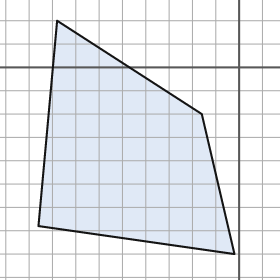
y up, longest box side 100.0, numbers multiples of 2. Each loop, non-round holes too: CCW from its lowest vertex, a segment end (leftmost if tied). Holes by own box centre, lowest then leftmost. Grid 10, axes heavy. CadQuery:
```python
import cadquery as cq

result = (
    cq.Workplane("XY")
    .moveTo(-2.0, -80.0)
    .lineTo(-16.0, -20.0)
    .lineTo(-78.0, 20.0)
    .lineTo(-86.0, -68.0)
    .close()
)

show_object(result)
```